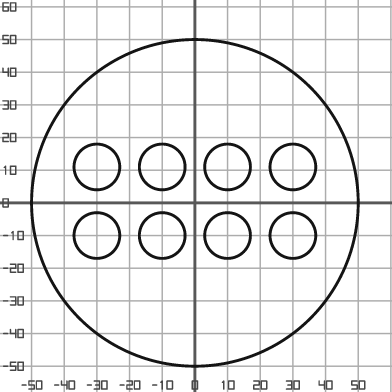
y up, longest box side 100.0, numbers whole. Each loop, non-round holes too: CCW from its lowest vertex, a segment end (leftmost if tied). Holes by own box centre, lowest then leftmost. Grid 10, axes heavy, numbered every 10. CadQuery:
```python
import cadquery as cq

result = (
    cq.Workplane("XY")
    .moveTo(0.0, 0.0)
    .circle(50.0)
    .moveTo(-30.0, -10.0)
    .circle(7.0)
    .moveTo(-10.0, -10.0)
    .circle(7.0)
    .moveTo(10.0, -10.0)
    .circle(7.0)
    .moveTo(30.0, -10.0)
    .circle(7.0)
    .moveTo(-30.0, 11.0)
    .circle(7.0)
    .moveTo(-10.0, 11.0)
    .circle(7.0)
    .moveTo(10.0, 11.0)
    .circle(7.0)
    .moveTo(30.0, 11.0)
    .circle(7.0)
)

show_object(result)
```